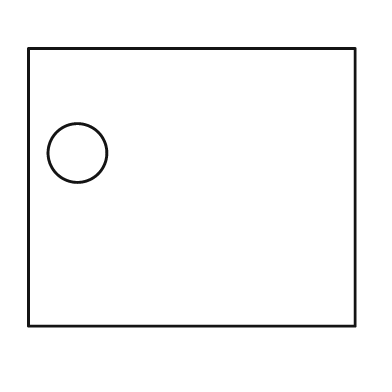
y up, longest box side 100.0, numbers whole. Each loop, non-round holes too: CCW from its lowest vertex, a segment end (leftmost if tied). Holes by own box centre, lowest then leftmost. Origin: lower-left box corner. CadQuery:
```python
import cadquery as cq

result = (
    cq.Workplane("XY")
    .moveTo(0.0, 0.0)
    .lineTo(100.0, 0.0)
    .lineTo(100.0, 85.0)
    .lineTo(0.0, 85.0)
    .close()
    .moveTo(15.0, 53.0)
    .circle(9.0)
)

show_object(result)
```